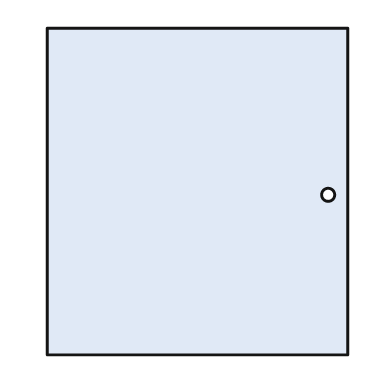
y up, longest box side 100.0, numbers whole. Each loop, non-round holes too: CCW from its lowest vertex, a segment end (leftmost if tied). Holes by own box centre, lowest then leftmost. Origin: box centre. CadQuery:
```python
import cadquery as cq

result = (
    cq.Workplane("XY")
    .moveTo(-46.0, -50.0)
    .lineTo(46.0, -50.0)
    .lineTo(46.0, 50.0)
    .lineTo(-46.0, 50.0)
    .close()
    .moveTo(40.0, -1.0)
    .circle(2.0)
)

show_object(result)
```